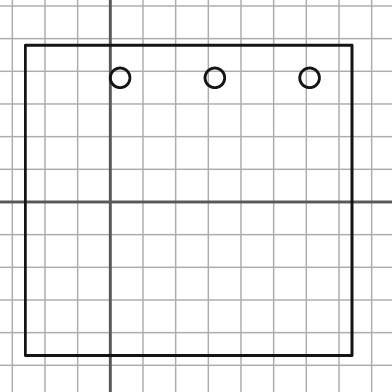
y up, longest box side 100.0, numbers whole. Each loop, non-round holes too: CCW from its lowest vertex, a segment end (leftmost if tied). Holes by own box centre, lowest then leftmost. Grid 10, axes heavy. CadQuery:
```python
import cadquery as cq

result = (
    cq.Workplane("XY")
    .moveTo(-26.0, -47.0)
    .lineTo(74.0, -47.0)
    .lineTo(74.0, 48.0)
    .lineTo(-26.0, 48.0)
    .close()
    .moveTo(3.0, 38.0)
    .circle(3.0)
    .moveTo(32.0, 38.0)
    .circle(3.0)
    .moveTo(61.0, 38.0)
    .circle(3.0)
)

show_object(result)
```